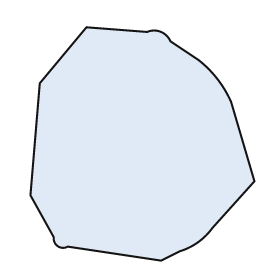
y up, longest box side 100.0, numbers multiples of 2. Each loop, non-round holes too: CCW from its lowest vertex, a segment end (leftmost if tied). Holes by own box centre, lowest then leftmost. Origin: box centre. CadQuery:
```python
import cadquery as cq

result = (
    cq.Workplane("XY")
    .moveTo(8.0, -50.0)
    .lineTo(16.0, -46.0)
    .threePointArc((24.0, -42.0), (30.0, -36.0))
    .lineTo(48.0, -16.0)
    .lineTo(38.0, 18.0)
    .threePointArc((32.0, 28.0), (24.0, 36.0))
    .lineTo(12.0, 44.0)
    .threePointArc((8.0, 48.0), (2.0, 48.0))
    .lineTo(-24.0, 50.0)
    .lineTo(-44.0, 26.0)
    .lineTo(-48.0, -22.0)
    .lineTo(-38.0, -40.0)
    .threePointArc((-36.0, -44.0), (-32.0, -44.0))
    .close()
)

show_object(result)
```